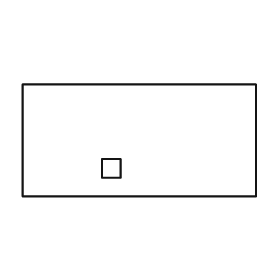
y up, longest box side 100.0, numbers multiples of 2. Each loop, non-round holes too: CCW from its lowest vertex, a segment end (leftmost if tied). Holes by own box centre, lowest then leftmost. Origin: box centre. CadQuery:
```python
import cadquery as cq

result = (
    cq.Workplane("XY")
    .moveTo(-50.0, -24.0)
    .lineTo(50.0, -24.0)
    .lineTo(50.0, 24.0)
    .lineTo(-50.0, 24.0)
    .close()
    .moveTo(-16.0, -16.0)
    .lineTo(-8.0, -16.0)
    .lineTo(-8.0, -8.0)
    .lineTo(-16.0, -8.0)
    .close()
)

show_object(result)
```